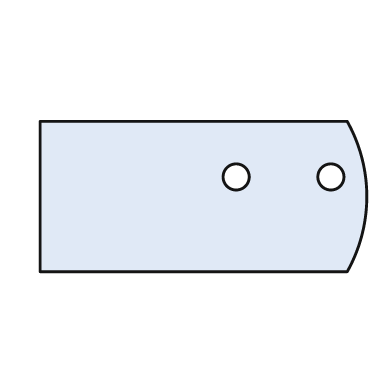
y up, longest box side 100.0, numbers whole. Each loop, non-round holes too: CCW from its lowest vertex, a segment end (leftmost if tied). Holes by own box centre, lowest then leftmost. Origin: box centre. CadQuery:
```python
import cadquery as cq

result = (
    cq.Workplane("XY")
    .moveTo(-50.0, -23.0)
    .lineTo(44.0, -23.0)
    .threePointArc((50.0, 0.0), (44.0, 23.0))
    .lineTo(-50.0, 23.0)
    .close()
    .moveTo(10.0, 6.0)
    .circle(4.0)
    .moveTo(39.0, 6.0)
    .circle(4.0)
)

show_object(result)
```